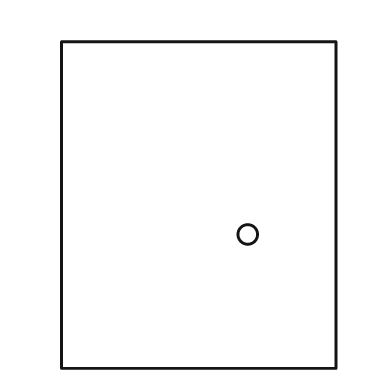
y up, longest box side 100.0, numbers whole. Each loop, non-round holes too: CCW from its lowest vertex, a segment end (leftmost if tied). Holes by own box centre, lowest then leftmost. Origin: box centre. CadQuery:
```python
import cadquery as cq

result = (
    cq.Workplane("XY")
    .moveTo(-42.0, -50.0)
    .lineTo(42.0, -50.0)
    .lineTo(42.0, 50.0)
    .lineTo(-42.0, 50.0)
    .close()
    .moveTo(15.0, -9.0)
    .circle(3.0)
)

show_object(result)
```